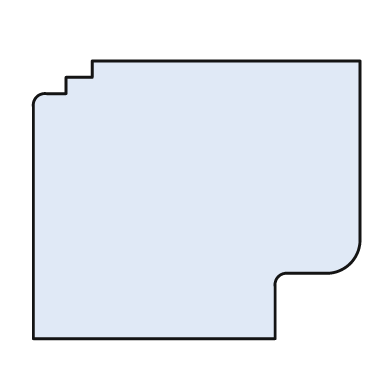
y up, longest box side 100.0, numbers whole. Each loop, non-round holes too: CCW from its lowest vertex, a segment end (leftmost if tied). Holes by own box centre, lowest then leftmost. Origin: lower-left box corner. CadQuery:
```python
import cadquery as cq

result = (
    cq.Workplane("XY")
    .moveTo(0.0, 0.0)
    .lineTo(74.0, 0.0)
    .lineTo(74.0, 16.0)
    .threePointArc((75.0, 19.0), (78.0, 20.0))
    .lineTo(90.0, 20.0)
    .threePointArc((97.0, 23.0), (100.0, 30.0))
    .lineTo(100.0, 85.0)
    .lineTo(18.0, 85.0)
    .lineTo(18.0, 80.0)
    .lineTo(10.0, 80.0)
    .lineTo(10.0, 75.0)
    .lineTo(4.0, 75.0)
    .threePointArc((1.0, 74.0), (0.0, 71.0))
    .close()
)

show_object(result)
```